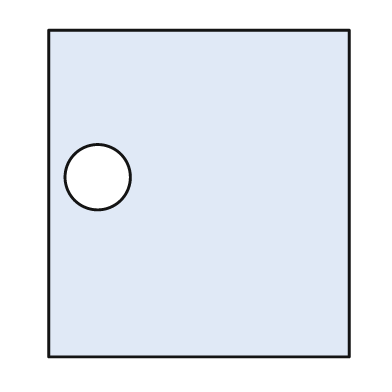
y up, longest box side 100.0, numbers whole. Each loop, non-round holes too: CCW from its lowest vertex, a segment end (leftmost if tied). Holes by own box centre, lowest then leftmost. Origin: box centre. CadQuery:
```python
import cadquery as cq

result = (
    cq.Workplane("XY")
    .moveTo(-46.0, -50.0)
    .lineTo(46.0, -50.0)
    .lineTo(46.0, 50.0)
    .lineTo(-46.0, 50.0)
    .close()
    .moveTo(-31.0, 5.0)
    .circle(10.0)
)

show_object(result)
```